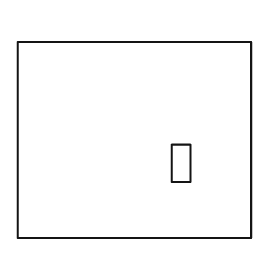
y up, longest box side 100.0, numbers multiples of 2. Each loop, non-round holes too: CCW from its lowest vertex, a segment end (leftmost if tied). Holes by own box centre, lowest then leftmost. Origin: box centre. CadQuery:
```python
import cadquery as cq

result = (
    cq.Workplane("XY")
    .moveTo(-50.0, -42.0)
    .lineTo(50.0, -42.0)
    .lineTo(50.0, 42.0)
    .lineTo(-50.0, 42.0)
    .close()
    .moveTo(16.0, -18.0)
    .lineTo(24.0, -18.0)
    .lineTo(24.0, -2.0)
    .lineTo(16.0, -2.0)
    .close()
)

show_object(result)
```